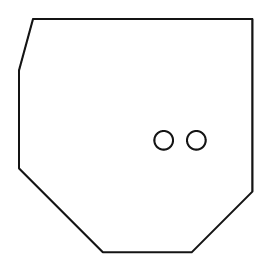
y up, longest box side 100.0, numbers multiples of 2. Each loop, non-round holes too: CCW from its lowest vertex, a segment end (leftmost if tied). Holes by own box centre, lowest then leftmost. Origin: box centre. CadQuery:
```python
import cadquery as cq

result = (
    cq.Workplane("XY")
    .moveTo(-14.0, -50.0)
    .lineTo(24.0, -50.0)
    .lineTo(50.0, -24.0)
    .lineTo(50.0, 50.0)
    .lineTo(-44.0, 50.0)
    .lineTo(-50.0, 28.0)
    .lineTo(-50.0, -14.0)
    .close()
    .moveTo(12.0, -2.0)
    .circle(4.0)
    .moveTo(26.0, -2.0)
    .circle(4.0)
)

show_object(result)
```